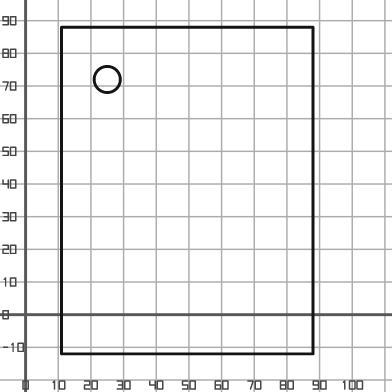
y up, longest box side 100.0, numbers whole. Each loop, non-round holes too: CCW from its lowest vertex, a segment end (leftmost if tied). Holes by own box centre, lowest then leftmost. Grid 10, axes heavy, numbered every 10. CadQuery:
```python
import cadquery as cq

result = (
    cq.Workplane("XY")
    .moveTo(11.0, -12.0)
    .lineTo(88.0, -12.0)
    .lineTo(88.0, 88.0)
    .lineTo(11.0, 88.0)
    .close()
    .moveTo(25.0, 72.0)
    .circle(4.0)
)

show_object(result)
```